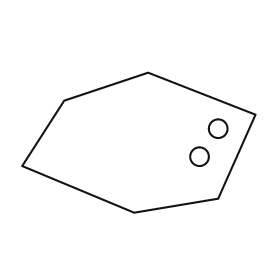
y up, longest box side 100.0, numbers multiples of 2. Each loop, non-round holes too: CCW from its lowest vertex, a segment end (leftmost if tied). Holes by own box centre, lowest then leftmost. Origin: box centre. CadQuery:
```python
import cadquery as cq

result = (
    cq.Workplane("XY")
    .moveTo(-2.0, -30.0)
    .lineTo(34.0, -24.0)
    .lineTo(50.0, 12.0)
    .lineTo(4.0, 30.0)
    .lineTo(-32.0, 18.0)
    .lineTo(-50.0, -10.0)
    .close()
    .moveTo(26.0, -6.0)
    .circle(4.0)
    .moveTo(34.0, 6.0)
    .circle(4.0)
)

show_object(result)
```